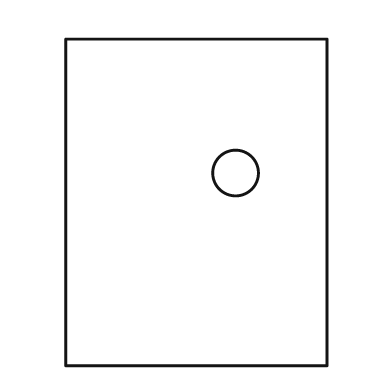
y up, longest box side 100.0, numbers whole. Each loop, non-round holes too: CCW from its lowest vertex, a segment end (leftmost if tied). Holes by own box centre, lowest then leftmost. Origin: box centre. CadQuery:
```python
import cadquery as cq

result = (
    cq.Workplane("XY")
    .moveTo(-40.0, -50.0)
    .lineTo(40.0, -50.0)
    .lineTo(40.0, 50.0)
    .lineTo(-40.0, 50.0)
    .close()
    .moveTo(12.0, 9.0)
    .circle(7.0)
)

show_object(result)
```